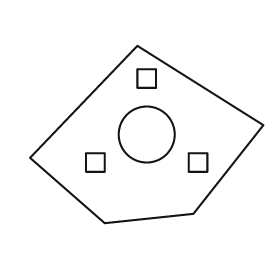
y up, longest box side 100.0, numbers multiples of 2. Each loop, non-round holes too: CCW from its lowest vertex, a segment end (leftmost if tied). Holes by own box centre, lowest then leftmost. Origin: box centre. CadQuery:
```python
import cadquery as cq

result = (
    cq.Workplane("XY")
    .moveTo(-18.0, -38.0)
    .lineTo(20.0, -34.0)
    .lineTo(50.0, 4.0)
    .lineTo(-4.0, 38.0)
    .lineTo(-50.0, -10.0)
    .close()
    .moveTo(-26.0, -16.0)
    .lineTo(-18.0, -16.0)
    .lineTo(-18.0, -8.0)
    .lineTo(-26.0, -8.0)
    .close()
    .moveTo(18.0, -16.0)
    .lineTo(26.0, -16.0)
    .lineTo(26.0, -8.0)
    .lineTo(18.0, -8.0)
    .close()
    .moveTo(0.0, 0.0)
    .circle(12.0)
    .moveTo(-4.0, 20.0)
    .lineTo(4.0, 20.0)
    .lineTo(4.0, 28.0)
    .lineTo(-4.0, 28.0)
    .close()
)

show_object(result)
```